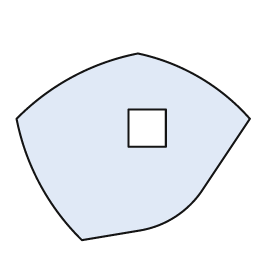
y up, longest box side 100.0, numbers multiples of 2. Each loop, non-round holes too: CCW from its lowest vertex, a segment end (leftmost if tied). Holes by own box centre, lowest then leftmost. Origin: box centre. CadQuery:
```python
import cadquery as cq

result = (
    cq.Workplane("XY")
    .moveTo(-22.0, -40.0)
    .lineTo(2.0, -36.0)
    .threePointArc((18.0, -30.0), (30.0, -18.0))
    .lineTo(50.0, 12.0)
    .threePointArc((28.0, 30.0), (2.0, 40.0))
    .threePointArc((-26.0, 30.0), (-50.0, 12.0))
    .threePointArc((-40.0, -16.0), (-22.0, -40.0))
    .close()
    .moveTo(-2.0, 0.0)
    .lineTo(14.0, 0.0)
    .lineTo(14.0, 16.0)
    .lineTo(-2.0, 16.0)
    .close()
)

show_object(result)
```